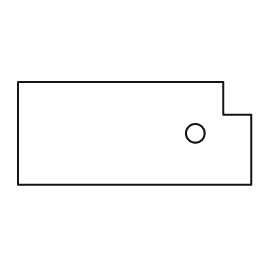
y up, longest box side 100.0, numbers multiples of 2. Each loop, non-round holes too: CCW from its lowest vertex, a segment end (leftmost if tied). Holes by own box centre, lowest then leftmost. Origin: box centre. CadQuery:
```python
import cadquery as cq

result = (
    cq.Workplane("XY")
    .moveTo(-50.0, -22.0)
    .lineTo(50.0, -22.0)
    .lineTo(50.0, 8.0)
    .lineTo(38.0, 8.0)
    .lineTo(38.0, 22.0)
    .lineTo(-50.0, 22.0)
    .close()
    .moveTo(26.0, 0.0)
    .circle(4.0)
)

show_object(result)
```